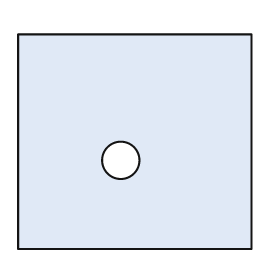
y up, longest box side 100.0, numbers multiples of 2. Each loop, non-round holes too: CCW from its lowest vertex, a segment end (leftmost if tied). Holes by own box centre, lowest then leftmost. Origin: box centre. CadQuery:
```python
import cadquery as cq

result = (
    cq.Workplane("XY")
    .moveTo(-50.0, -46.0)
    .lineTo(50.0, -46.0)
    .lineTo(50.0, 46.0)
    .lineTo(-50.0, 46.0)
    .close()
    .moveTo(-6.0, -8.0)
    .circle(8.0)
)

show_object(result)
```